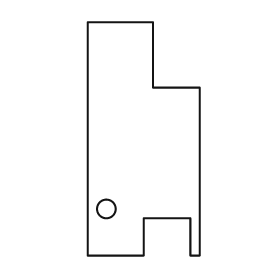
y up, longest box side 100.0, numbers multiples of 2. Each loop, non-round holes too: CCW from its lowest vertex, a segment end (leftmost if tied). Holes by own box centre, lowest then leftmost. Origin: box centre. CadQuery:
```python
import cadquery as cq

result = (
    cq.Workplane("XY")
    .moveTo(-24.0, -50.0)
    .lineTo(0.0, -50.0)
    .lineTo(0.0, -34.0)
    .lineTo(20.0, -34.0)
    .lineTo(20.0, -50.0)
    .lineTo(24.0, -50.0)
    .lineTo(24.0, 22.0)
    .lineTo(4.0, 22.0)
    .lineTo(4.0, 50.0)
    .lineTo(-24.0, 50.0)
    .close()
    .moveTo(-16.0, -30.0)
    .circle(4.0)
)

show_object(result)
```